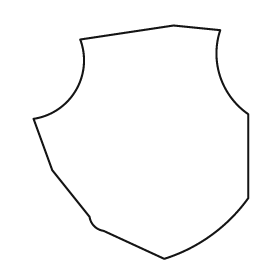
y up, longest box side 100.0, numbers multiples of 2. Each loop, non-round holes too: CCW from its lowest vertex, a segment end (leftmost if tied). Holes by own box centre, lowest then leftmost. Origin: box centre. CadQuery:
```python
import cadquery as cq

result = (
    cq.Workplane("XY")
    .moveTo(10.0, -50.0)
    .threePointArc((30.0, -40.0), (46.0, -24.0))
    .lineTo(46.0, 12.0)
    .threePointArc((34.0, 28.0), (34.0, 48.0))
    .lineTo(14.0, 50.0)
    .lineTo(-26.0, 44.0)
    .threePointArc((-28.0, 22.0), (-46.0, 10.0))
    .lineTo(-38.0, -12.0)
    .lineTo(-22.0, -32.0)
    .threePointArc((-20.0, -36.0), (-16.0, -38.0))
    .close()
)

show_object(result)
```